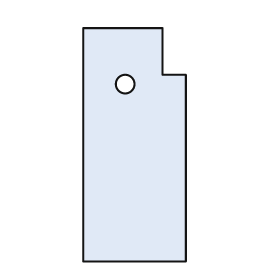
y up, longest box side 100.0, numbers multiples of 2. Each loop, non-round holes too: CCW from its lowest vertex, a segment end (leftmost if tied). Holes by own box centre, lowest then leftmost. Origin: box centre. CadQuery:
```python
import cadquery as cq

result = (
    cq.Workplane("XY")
    .moveTo(-22.0, -50.0)
    .lineTo(22.0, -50.0)
    .lineTo(22.0, 30.0)
    .lineTo(12.0, 30.0)
    .lineTo(12.0, 50.0)
    .lineTo(-22.0, 50.0)
    .close()
    .moveTo(-4.0, 26.0)
    .circle(4.0)
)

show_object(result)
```